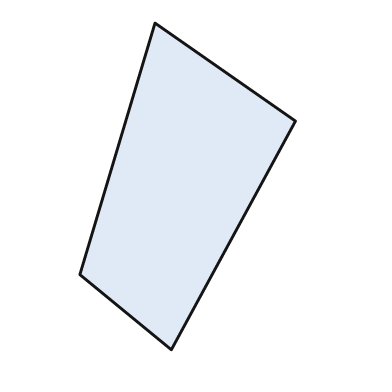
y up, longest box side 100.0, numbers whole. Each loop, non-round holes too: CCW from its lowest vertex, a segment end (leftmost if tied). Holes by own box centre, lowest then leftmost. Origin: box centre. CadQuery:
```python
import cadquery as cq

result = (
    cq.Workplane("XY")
    .moveTo(-5.0, -50.0)
    .lineTo(33.0, 20.0)
    .lineTo(-10.0, 50.0)
    .lineTo(-33.0, -27.0)
    .close()
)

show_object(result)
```